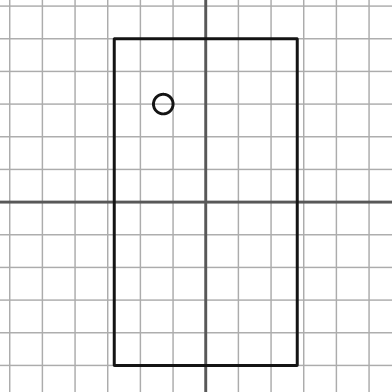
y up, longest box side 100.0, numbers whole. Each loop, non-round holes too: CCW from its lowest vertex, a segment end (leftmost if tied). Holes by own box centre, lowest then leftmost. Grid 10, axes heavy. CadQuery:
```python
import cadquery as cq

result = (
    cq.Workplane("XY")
    .moveTo(-28.0, -50.0)
    .lineTo(28.0, -50.0)
    .lineTo(28.0, 50.0)
    .lineTo(-28.0, 50.0)
    .close()
    .moveTo(-13.0, 30.0)
    .circle(3.0)
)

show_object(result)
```